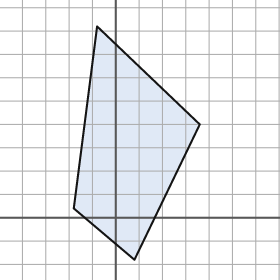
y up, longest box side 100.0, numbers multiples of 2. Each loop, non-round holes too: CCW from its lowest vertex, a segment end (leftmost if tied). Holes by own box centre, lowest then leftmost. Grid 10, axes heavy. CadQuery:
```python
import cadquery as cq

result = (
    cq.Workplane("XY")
    .moveTo(8.0, -18.0)
    .lineTo(36.0, 40.0)
    .lineTo(-8.0, 82.0)
    .lineTo(-18.0, 4.0)
    .close()
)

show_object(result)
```